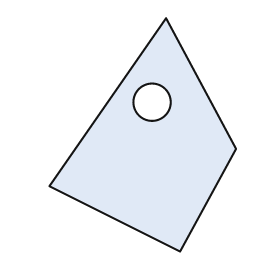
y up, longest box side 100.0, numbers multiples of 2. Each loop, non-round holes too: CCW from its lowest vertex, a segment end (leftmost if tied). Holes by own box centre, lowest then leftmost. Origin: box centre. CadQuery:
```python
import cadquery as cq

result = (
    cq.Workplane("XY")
    .moveTo(16.0, -50.0)
    .lineTo(40.0, -6.0)
    .lineTo(10.0, 50.0)
    .lineTo(-40.0, -22.0)
    .close()
    .moveTo(4.0, 14.0)
    .circle(8.0)
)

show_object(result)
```